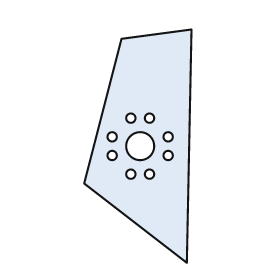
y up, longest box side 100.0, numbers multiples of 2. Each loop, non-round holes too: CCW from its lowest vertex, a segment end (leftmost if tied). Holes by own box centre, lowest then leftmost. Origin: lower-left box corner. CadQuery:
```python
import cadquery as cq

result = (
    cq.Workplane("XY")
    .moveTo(44.0, 0.0)
    .lineTo(46.0, 100.0)
    .lineTo(16.0, 96.0)
    .lineTo(0.0, 34.0)
    .close()
    .moveTo(20.0, 38.0)
    .circle(2.0)
    .moveTo(28.0, 38.0)
    .circle(2.0)
    .moveTo(12.0, 46.0)
    .circle(2.0)
    .moveTo(36.0, 46.0)
    .circle(2.0)
    .moveTo(24.0, 50.0)
    .circle(6.0)
    .moveTo(12.0, 54.0)
    .circle(2.0)
    .moveTo(36.0, 54.0)
    .circle(2.0)
    .moveTo(20.0, 62.0)
    .circle(2.0)
    .moveTo(28.0, 62.0)
    .circle(2.0)
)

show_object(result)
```